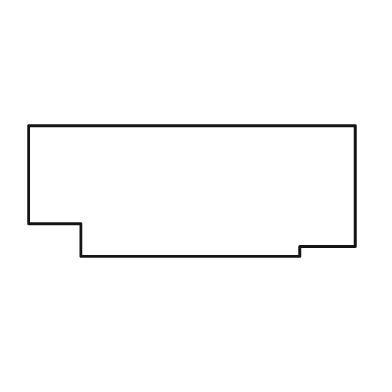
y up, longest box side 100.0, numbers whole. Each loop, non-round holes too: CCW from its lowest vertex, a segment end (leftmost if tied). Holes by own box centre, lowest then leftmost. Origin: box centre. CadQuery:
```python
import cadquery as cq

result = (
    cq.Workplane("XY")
    .moveTo(-34.0, -20.0)
    .lineTo(33.0, -20.0)
    .lineTo(33.0, -17.0)
    .lineTo(50.0, -17.0)
    .lineTo(50.0, 20.0)
    .lineTo(-50.0, 20.0)
    .lineTo(-50.0, -10.0)
    .lineTo(-34.0, -10.0)
    .close()
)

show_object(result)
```